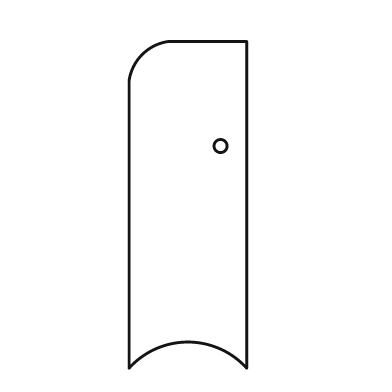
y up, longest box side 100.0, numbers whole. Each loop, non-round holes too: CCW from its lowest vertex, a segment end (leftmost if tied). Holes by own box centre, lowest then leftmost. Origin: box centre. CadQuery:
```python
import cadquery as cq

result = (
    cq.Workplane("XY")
    .moveTo(-18.0, -50.0)
    .threePointArc((0.0, -42.0), (18.0, -50.0))
    .lineTo(18.0, 50.0)
    .lineTo(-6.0, 50.0)
    .threePointArc((-14.0, 46.0), (-18.0, 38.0))
    .close()
    .moveTo(10.0, 18.0)
    .circle(2.0)
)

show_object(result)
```